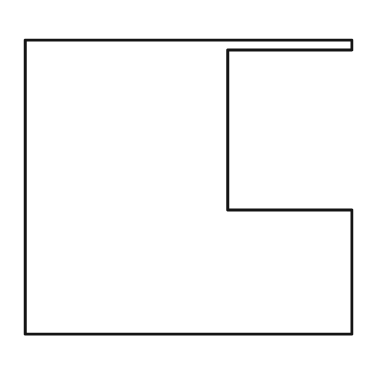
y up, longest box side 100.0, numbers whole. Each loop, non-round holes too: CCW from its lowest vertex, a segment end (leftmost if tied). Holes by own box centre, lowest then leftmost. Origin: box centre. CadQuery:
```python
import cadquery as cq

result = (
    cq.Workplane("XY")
    .moveTo(-50.0, -45.0)
    .lineTo(50.0, -45.0)
    .lineTo(50.0, -7.0)
    .lineTo(12.0, -7.0)
    .lineTo(12.0, 42.0)
    .lineTo(50.0, 42.0)
    .lineTo(50.0, 45.0)
    .lineTo(-50.0, 45.0)
    .close()
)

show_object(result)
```